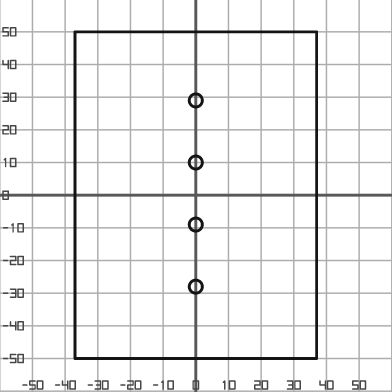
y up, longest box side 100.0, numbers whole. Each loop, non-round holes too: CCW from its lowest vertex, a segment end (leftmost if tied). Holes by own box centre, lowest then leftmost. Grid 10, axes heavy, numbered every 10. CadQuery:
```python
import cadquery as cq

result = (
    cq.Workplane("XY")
    .moveTo(-37.0, -50.0)
    .lineTo(37.0, -50.0)
    .lineTo(37.0, 50.0)
    .lineTo(-37.0, 50.0)
    .close()
    .moveTo(0.0, -28.0)
    .circle(2.0)
    .moveTo(0.0, -9.0)
    .circle(2.0)
    .moveTo(0.0, 10.0)
    .circle(2.0)
    .moveTo(0.0, 29.0)
    .circle(2.0)
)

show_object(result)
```